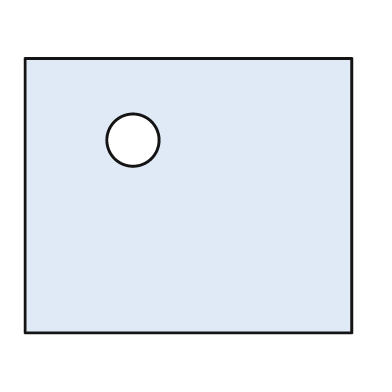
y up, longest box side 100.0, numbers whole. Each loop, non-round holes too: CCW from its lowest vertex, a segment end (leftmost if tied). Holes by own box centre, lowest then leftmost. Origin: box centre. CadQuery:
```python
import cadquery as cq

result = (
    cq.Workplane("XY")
    .moveTo(-50.0, -42.0)
    .lineTo(50.0, -42.0)
    .lineTo(50.0, 42.0)
    .lineTo(-50.0, 42.0)
    .close()
    .moveTo(-17.0, 17.0)
    .circle(8.0)
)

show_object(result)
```